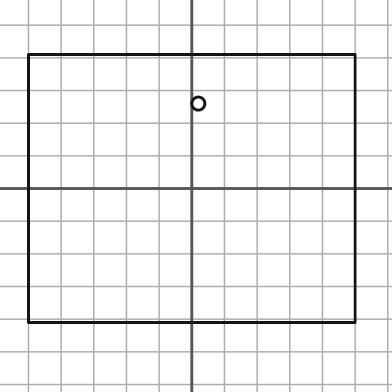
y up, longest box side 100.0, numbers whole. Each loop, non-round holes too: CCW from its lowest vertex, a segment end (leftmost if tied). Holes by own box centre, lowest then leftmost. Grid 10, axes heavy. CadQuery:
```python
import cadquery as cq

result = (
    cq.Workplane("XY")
    .moveTo(-50.0, -41.0)
    .lineTo(50.0, -41.0)
    .lineTo(50.0, 41.0)
    .lineTo(-50.0, 41.0)
    .close()
    .moveTo(2.0, 26.0)
    .circle(2.0)
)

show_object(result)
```